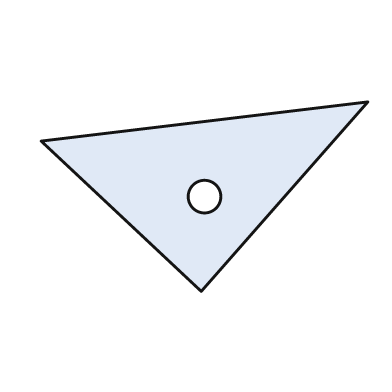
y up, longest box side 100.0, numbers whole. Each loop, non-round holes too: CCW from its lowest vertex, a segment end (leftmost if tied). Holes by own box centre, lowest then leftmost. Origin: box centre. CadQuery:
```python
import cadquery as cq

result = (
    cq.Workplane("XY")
    .moveTo(-1.0, -29.0)
    .lineTo(50.0, 29.0)
    .lineTo(-50.0, 17.0)
    .close()
    .moveTo(0.0, 0.0)
    .circle(5.0)
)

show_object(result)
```